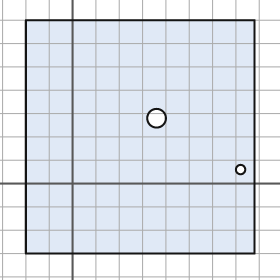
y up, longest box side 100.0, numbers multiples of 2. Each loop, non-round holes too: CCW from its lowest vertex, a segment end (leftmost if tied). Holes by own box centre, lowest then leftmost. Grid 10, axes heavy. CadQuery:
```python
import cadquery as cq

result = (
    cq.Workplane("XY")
    .moveTo(-20.0, -30.0)
    .lineTo(78.0, -30.0)
    .lineTo(78.0, 70.0)
    .lineTo(-20.0, 70.0)
    .close()
    .moveTo(72.0, 6.0)
    .circle(2.0)
    .moveTo(36.0, 28.0)
    .circle(4.0)
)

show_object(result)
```